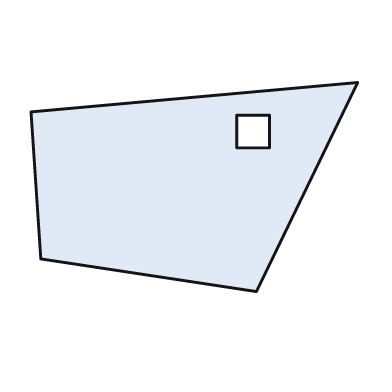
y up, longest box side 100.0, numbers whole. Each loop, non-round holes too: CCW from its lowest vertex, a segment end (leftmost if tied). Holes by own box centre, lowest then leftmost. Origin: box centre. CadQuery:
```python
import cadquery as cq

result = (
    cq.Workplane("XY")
    .moveTo(19.0, -32.0)
    .lineTo(50.0, 32.0)
    .lineTo(-50.0, 23.0)
    .lineTo(-47.0, -22.0)
    .close()
    .moveTo(13.0, 12.0)
    .lineTo(23.0, 12.0)
    .lineTo(23.0, 22.0)
    .lineTo(13.0, 22.0)
    .close()
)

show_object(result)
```